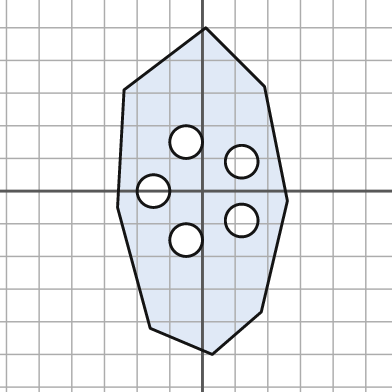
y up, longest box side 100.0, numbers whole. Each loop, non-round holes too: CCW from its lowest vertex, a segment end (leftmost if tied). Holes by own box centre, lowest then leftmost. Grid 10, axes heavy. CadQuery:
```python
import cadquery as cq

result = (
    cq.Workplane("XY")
    .moveTo(3.0, -50.0)
    .lineTo(18.0, -37.0)
    .lineTo(26.0, -3.0)
    .lineTo(19.0, 32.0)
    .lineTo(1.0, 50.0)
    .lineTo(-24.0, 31.0)
    .lineTo(-26.0, -5.0)
    .lineTo(-16.0, -42.0)
    .close()
    .moveTo(-5.0, -15.0)
    .circle(5.0)
    .moveTo(12.0, -9.0)
    .circle(5.0)
    .moveTo(-15.0, 0.0)
    .circle(5.0)
    .moveTo(12.0, 9.0)
    .circle(5.0)
    .moveTo(-5.0, 15.0)
    .circle(5.0)
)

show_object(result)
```